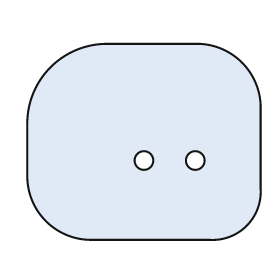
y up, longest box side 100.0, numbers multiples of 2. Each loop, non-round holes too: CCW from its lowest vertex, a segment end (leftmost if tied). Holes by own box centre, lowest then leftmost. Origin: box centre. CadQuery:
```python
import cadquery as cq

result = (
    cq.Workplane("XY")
    .moveTo(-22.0, -42.0)
    .lineTo(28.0, -42.0)
    .threePointArc((44.0, -36.0), (50.0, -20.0))
    .lineTo(50.0, 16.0)
    .threePointArc((42.0, 34.0), (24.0, 42.0))
    .lineTo(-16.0, 42.0)
    .threePointArc((-40.0, 32.0), (-50.0, 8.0))
    .lineTo(-50.0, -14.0)
    .threePointArc((-42.0, -34.0), (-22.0, -42.0))
    .close()
    .moveTo(0.0, -8.0)
    .circle(4.0)
    .moveTo(22.0, -8.0)
    .circle(4.0)
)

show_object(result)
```